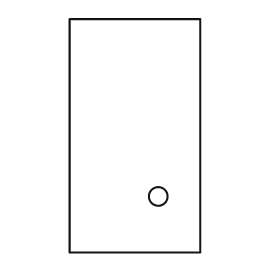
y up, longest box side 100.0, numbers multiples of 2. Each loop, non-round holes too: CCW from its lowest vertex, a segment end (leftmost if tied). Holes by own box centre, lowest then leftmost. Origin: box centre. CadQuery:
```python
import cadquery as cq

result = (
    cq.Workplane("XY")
    .moveTo(-28.0, -50.0)
    .lineTo(28.0, -50.0)
    .lineTo(28.0, 50.0)
    .lineTo(-28.0, 50.0)
    .close()
    .moveTo(10.0, -26.0)
    .circle(4.0)
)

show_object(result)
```